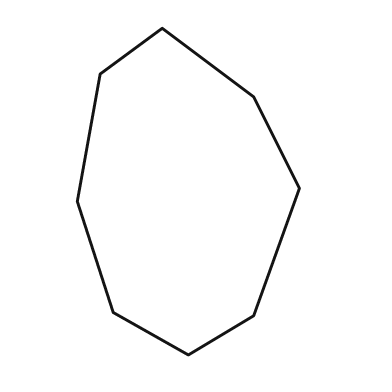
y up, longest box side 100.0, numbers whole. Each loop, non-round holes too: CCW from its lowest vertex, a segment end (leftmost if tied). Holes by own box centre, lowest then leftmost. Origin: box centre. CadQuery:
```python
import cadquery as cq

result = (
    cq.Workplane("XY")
    .moveTo(0.0, -50.0)
    .lineTo(20.0, -38.0)
    .lineTo(34.0, 1.0)
    .lineTo(20.0, 29.0)
    .lineTo(-8.0, 50.0)
    .lineTo(-27.0, 36.0)
    .lineTo(-34.0, -3.0)
    .lineTo(-23.0, -37.0)
    .close()
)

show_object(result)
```